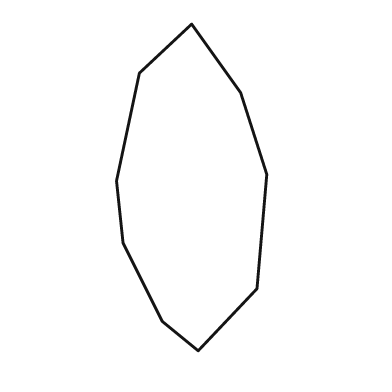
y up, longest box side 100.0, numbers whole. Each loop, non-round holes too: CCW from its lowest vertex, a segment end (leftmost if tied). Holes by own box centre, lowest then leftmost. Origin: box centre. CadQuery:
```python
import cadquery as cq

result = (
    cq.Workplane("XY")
    .moveTo(2.0, -50.0)
    .lineTo(20.0, -31.0)
    .lineTo(23.0, 4.0)
    .lineTo(15.0, 29.0)
    .lineTo(0.0, 50.0)
    .lineTo(-16.0, 35.0)
    .lineTo(-23.0, 2.0)
    .lineTo(-21.0, -17.0)
    .lineTo(-9.0, -41.0)
    .close()
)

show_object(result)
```